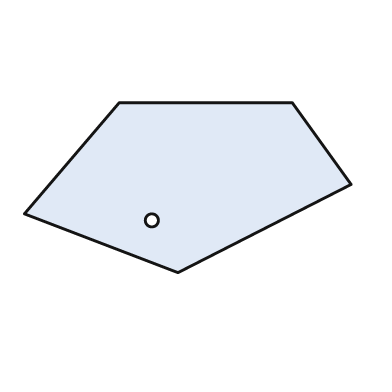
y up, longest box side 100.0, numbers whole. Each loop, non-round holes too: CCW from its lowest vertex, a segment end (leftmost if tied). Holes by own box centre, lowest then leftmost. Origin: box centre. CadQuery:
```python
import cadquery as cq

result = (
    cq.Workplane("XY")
    .moveTo(-3.0, -26.0)
    .lineTo(50.0, 1.0)
    .lineTo(32.0, 26.0)
    .lineTo(-21.0, 26.0)
    .lineTo(-50.0, -8.0)
    .close()
    .moveTo(-11.0, -10.0)
    .circle(2.0)
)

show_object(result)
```